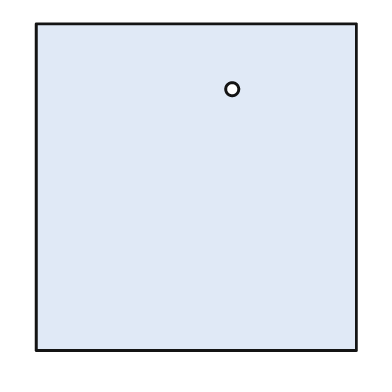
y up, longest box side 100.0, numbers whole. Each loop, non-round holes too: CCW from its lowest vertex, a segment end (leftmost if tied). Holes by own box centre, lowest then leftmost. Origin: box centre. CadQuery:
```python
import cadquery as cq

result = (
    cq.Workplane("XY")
    .moveTo(-49.0, -50.0)
    .lineTo(49.0, -50.0)
    .lineTo(49.0, 50.0)
    .lineTo(-49.0, 50.0)
    .close()
    .moveTo(11.0, 30.0)
    .circle(2.0)
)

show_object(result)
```